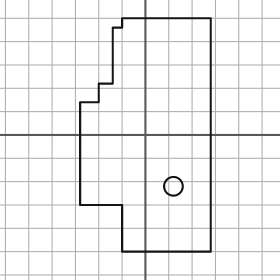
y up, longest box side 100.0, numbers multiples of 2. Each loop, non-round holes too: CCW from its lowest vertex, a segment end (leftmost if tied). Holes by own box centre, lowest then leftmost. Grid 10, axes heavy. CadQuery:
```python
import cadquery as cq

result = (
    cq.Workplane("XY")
    .moveTo(-10.0, -50.0)
    .lineTo(28.0, -50.0)
    .lineTo(28.0, 50.0)
    .lineTo(-10.0, 50.0)
    .lineTo(-10.0, 46.0)
    .lineTo(-14.0, 46.0)
    .lineTo(-14.0, 22.0)
    .lineTo(-20.0, 22.0)
    .lineTo(-20.0, 14.0)
    .lineTo(-28.0, 14.0)
    .lineTo(-28.0, -30.0)
    .lineTo(-10.0, -30.0)
    .close()
    .moveTo(12.0, -22.0)
    .circle(4.0)
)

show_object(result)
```